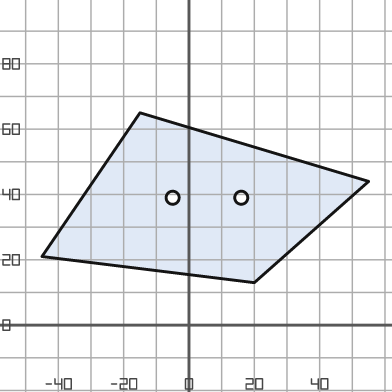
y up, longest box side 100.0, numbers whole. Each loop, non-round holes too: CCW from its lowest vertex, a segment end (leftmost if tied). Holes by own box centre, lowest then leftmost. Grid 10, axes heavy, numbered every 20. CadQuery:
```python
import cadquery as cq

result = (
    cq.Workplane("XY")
    .moveTo(20.0, 13.0)
    .lineTo(55.0, 44.0)
    .lineTo(-15.0, 65.0)
    .lineTo(-45.0, 21.0)
    .close()
    .moveTo(-5.0, 39.0)
    .circle(2.0)
    .moveTo(16.0, 39.0)
    .circle(2.0)
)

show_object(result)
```